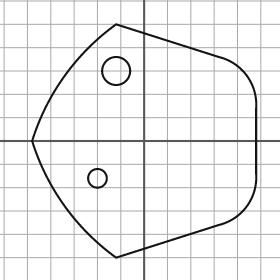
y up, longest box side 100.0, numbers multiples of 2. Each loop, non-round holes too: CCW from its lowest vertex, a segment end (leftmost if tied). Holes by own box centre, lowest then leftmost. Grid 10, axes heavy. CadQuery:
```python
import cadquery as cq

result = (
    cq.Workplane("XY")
    .moveTo(-12.0, -50.0)
    .lineTo(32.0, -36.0)
    .threePointArc((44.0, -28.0), (48.0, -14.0))
    .lineTo(48.0, 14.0)
    .threePointArc((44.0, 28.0), (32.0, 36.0))
    .lineTo(-12.0, 50.0)
    .threePointArc((-34.0, 28.0), (-48.0, 0.0))
    .threePointArc((-34.0, -28.0), (-12.0, -50.0))
    .close()
    .moveTo(-20.0, -16.0)
    .circle(4.0)
    .moveTo(-12.0, 30.0)
    .circle(6.0)
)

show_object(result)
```